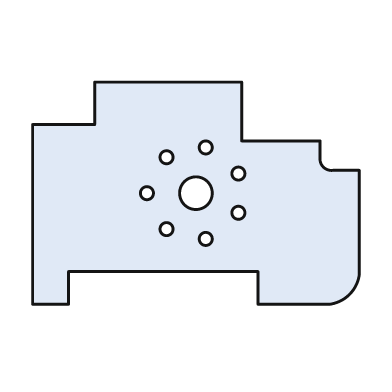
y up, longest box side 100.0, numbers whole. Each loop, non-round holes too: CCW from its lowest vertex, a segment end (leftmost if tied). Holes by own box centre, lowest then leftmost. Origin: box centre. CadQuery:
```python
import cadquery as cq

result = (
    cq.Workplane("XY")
    .moveTo(-50.0, -34.0)
    .lineTo(-39.0, -34.0)
    .lineTo(-39.0, -24.0)
    .lineTo(19.0, -24.0)
    .lineTo(19.0, -34.0)
    .lineTo(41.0, -34.0)
    .threePointArc((47.0, -31.0), (50.0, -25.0))
    .lineTo(50.0, 7.0)
    .lineTo(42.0, 7.0)
    .threePointArc((39.0, 8.0), (38.0, 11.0))
    .lineTo(38.0, 16.0)
    .lineTo(14.0, 16.0)
    .lineTo(14.0, 34.0)
    .lineTo(-31.0, 34.0)
    .lineTo(-31.0, 21.0)
    .lineTo(-50.0, 21.0)
    .close()
    .moveTo(3.0, -14.0)
    .circle(2.0)
    .moveTo(-9.0, -11.0)
    .circle(2.0)
    .moveTo(13.0, -6.0)
    .circle(2.0)
    .moveTo(-15.0, 0.0)
    .circle(2.0)
    .moveTo(0.0, 0.0)
    .circle(5.0)
    .moveTo(13.0, 6.0)
    .circle(2.0)
    .moveTo(-9.0, 11.0)
    .circle(2.0)
    .moveTo(3.0, 14.0)
    .circle(2.0)
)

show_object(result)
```